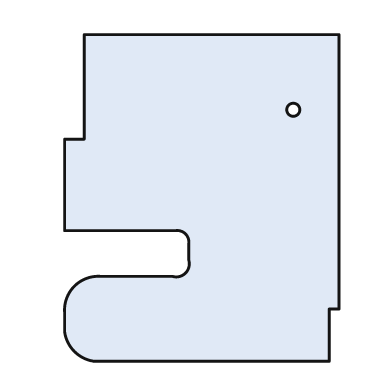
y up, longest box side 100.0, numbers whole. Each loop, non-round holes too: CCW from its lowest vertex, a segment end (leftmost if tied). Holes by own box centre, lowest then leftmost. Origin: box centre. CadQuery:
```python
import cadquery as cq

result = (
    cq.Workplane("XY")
    .moveTo(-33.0, -50.0)
    .lineTo(39.0, -50.0)
    .lineTo(39.0, -34.0)
    .lineTo(42.0, -34.0)
    .lineTo(42.0, 50.0)
    .lineTo(-36.0, 50.0)
    .lineTo(-36.0, 18.0)
    .lineTo(-42.0, 18.0)
    .lineTo(-42.0, -10.0)
    .lineTo(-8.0, -10.0)
    .threePointArc((-5.0, -11.0), (-4.0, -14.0))
    .lineTo(-4.0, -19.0)
    .threePointArc((-5.0, -23.0), (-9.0, -24.0))
    .lineTo(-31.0, -24.0)
    .threePointArc((-39.0, -27.0), (-42.0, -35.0))
    .lineTo(-42.0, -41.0)
    .threePointArc((-39.0, -47.0), (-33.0, -50.0))
    .close()
    .moveTo(28.0, 27.0)
    .circle(2.0)
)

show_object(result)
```